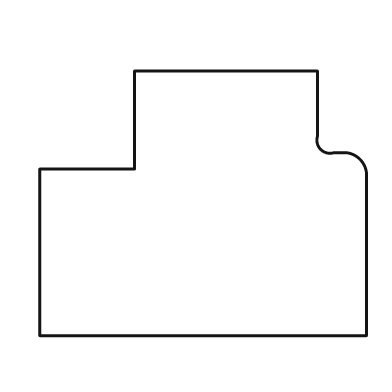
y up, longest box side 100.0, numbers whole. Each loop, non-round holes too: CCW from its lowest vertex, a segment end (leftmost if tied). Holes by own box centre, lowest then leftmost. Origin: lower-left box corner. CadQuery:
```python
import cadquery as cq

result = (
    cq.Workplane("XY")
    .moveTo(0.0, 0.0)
    .lineTo(100.0, 0.0)
    .lineTo(100.0, 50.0)
    .threePointArc((98.0, 54.0), (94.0, 56.0))
    .lineTo(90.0, 56.0)
    .threePointArc((86.0, 57.0), (85.0, 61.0))
    .lineTo(85.0, 81.0)
    .lineTo(29.0, 81.0)
    .lineTo(29.0, 51.0)
    .lineTo(0.0, 51.0)
    .close()
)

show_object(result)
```